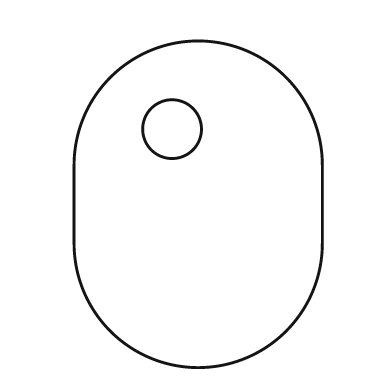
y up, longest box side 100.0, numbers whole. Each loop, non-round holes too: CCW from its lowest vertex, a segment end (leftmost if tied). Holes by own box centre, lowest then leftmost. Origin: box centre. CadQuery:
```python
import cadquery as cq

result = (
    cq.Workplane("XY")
    .moveTo(-38.0, -12.0)
    .threePointArc((0.0, -50.0), (38.0, -12.0))
    .lineTo(38.0, 12.0)
    .threePointArc((0.0, 50.0), (-38.0, 12.0))
    .close()
    .moveTo(-8.0, 23.0)
    .circle(9.0)
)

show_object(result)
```